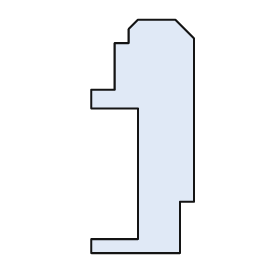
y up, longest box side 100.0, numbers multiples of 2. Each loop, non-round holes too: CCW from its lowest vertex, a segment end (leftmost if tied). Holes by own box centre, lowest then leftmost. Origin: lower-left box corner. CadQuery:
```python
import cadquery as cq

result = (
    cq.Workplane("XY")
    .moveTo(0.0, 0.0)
    .lineTo(38.0, 0.0)
    .lineTo(38.0, 22.0)
    .lineTo(44.0, 22.0)
    .lineTo(44.0, 92.0)
    .lineTo(36.0, 100.0)
    .lineTo(20.0, 100.0)
    .lineTo(16.0, 96.0)
    .lineTo(16.0, 90.0)
    .lineTo(10.0, 90.0)
    .lineTo(10.0, 70.0)
    .lineTo(0.0, 70.0)
    .lineTo(0.0, 62.0)
    .lineTo(20.0, 62.0)
    .lineTo(20.0, 6.0)
    .lineTo(0.0, 6.0)
    .close()
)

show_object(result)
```